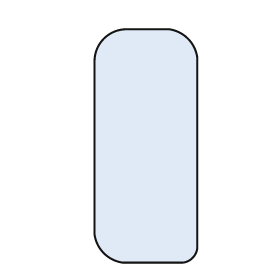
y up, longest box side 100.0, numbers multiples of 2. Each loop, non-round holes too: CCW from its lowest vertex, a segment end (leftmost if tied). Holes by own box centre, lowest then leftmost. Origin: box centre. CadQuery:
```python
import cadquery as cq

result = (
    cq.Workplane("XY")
    .moveTo(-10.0, -50.0)
    .lineTo(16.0, -50.0)
    .threePointArc((20.0, -48.0), (22.0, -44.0))
    .lineTo(22.0, 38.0)
    .threePointArc((18.0, 46.0), (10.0, 50.0))
    .lineTo(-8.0, 50.0)
    .threePointArc((-18.0, 46.0), (-22.0, 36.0))
    .lineTo(-22.0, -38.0)
    .threePointArc((-18.0, -46.0), (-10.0, -50.0))
    .close()
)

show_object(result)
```